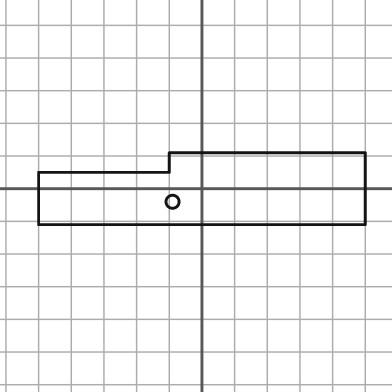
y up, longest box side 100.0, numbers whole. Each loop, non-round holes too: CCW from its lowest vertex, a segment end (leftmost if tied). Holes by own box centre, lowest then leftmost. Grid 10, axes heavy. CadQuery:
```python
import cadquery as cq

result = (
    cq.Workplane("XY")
    .moveTo(-50.0, -11.0)
    .lineTo(50.0, -11.0)
    .lineTo(50.0, 11.0)
    .lineTo(-10.0, 11.0)
    .lineTo(-10.0, 5.0)
    .lineTo(-50.0, 5.0)
    .close()
    .moveTo(-9.0, -4.0)
    .circle(2.0)
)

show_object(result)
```